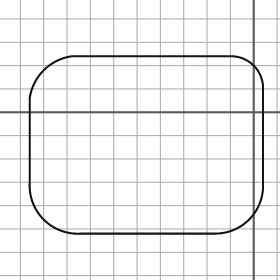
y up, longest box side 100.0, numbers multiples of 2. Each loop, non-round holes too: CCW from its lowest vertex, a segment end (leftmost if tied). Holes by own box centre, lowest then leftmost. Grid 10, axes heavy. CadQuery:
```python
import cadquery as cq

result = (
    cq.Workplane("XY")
    .moveTo(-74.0, -52.0)
    .lineTo(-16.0, -52.0)
    .threePointArc((-2.0, -46.0), (4.0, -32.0))
    .lineTo(4.0, 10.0)
    .threePointArc((0.0, 20.0), (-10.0, 24.0))
    .lineTo(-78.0, 24.0)
    .threePointArc((-90.0, 18.0), (-96.0, 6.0))
    .lineTo(-96.0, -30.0)
    .threePointArc((-90.0, -46.0), (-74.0, -52.0))
    .close()
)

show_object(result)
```